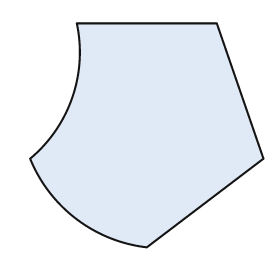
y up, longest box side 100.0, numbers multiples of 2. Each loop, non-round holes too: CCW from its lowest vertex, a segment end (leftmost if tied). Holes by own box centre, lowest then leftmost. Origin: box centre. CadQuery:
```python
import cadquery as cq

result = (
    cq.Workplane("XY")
    .moveTo(0.0, -48.0)
    .lineTo(50.0, -10.0)
    .lineTo(30.0, 48.0)
    .lineTo(-30.0, 48.0)
    .threePointArc((-32.0, 16.0), (-50.0, -10.0))
    .threePointArc((-30.0, -36.0), (0.0, -48.0))
    .close()
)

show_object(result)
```